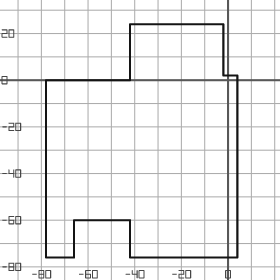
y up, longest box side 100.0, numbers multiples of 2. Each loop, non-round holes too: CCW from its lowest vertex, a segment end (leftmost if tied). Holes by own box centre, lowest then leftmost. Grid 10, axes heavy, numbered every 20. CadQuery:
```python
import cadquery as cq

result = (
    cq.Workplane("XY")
    .moveTo(-78.0, -76.0)
    .lineTo(-66.0, -76.0)
    .lineTo(-66.0, -60.0)
    .lineTo(-42.0, -60.0)
    .lineTo(-42.0, -76.0)
    .lineTo(4.0, -76.0)
    .lineTo(4.0, 2.0)
    .lineTo(-2.0, 2.0)
    .lineTo(-2.0, 24.0)
    .lineTo(-42.0, 24.0)
    .lineTo(-42.0, 0.0)
    .lineTo(-78.0, 0.0)
    .close()
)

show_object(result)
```